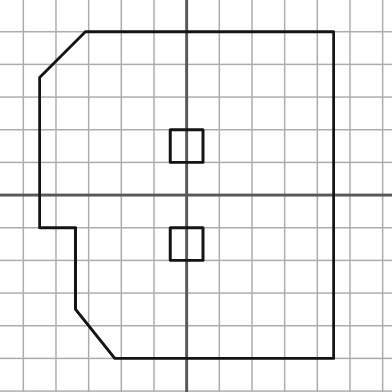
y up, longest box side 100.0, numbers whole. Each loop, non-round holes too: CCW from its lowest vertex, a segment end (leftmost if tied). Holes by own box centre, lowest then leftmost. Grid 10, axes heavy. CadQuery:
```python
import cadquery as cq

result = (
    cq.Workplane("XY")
    .moveTo(-22.0, -50.0)
    .lineTo(45.0, -50.0)
    .lineTo(45.0, 50.0)
    .lineTo(-31.0, 50.0)
    .lineTo(-45.0, 36.0)
    .lineTo(-45.0, -10.0)
    .lineTo(-34.0, -10.0)
    .lineTo(-34.0, -35.0)
    .close()
    .moveTo(-5.0, -20.0)
    .lineTo(5.0, -20.0)
    .lineTo(5.0, -10.0)
    .lineTo(-5.0, -10.0)
    .close()
    .moveTo(-5.0, 10.0)
    .lineTo(5.0, 10.0)
    .lineTo(5.0, 20.0)
    .lineTo(-5.0, 20.0)
    .close()
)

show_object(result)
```